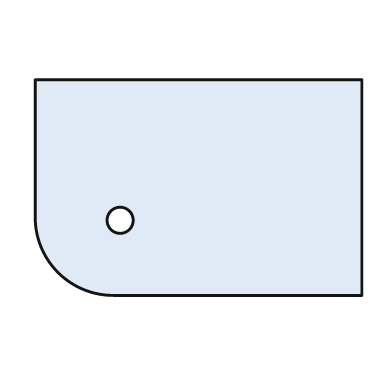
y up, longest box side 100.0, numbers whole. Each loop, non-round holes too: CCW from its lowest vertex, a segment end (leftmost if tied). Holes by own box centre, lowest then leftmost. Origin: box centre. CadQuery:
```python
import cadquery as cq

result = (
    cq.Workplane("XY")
    .moveTo(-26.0, -33.0)
    .lineTo(50.0, -33.0)
    .lineTo(50.0, 33.0)
    .lineTo(-50.0, 33.0)
    .lineTo(-50.0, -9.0)
    .threePointArc((-43.0, -26.0), (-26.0, -33.0))
    .close()
    .moveTo(-24.0, -10.0)
    .circle(4.0)
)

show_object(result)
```